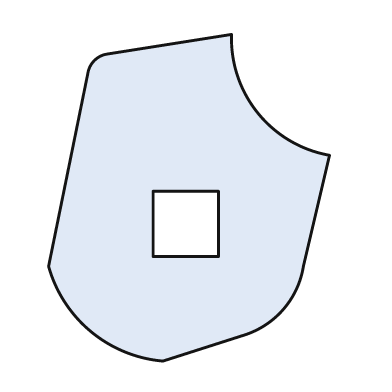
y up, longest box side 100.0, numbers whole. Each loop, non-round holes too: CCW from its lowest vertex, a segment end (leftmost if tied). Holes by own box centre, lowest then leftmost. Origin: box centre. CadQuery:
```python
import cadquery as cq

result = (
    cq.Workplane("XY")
    .moveTo(-8.0, -50.0)
    .lineTo(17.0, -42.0)
    .threePointArc((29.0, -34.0), (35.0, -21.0))
    .lineTo(43.0, 13.0)
    .threePointArc((21.0, 26.0), (13.0, 50.0))
    .lineTo(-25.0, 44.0)
    .threePointArc((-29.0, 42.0), (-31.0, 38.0))
    .lineTo(-43.0, -21.0)
    .threePointArc((-30.0, -41.0), (-8.0, -50.0))
    .close()
    .moveTo(-11.0, -18.0)
    .lineTo(9.0, -18.0)
    .lineTo(9.0, 2.0)
    .lineTo(-11.0, 2.0)
    .close()
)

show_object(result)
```